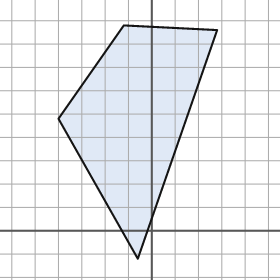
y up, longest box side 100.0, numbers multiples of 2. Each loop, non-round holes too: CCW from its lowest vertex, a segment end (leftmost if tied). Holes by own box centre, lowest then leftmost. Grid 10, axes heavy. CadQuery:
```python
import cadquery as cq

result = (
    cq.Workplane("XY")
    .moveTo(-6.0, -12.0)
    .lineTo(28.0, 86.0)
    .lineTo(-12.0, 88.0)
    .lineTo(-40.0, 48.0)
    .close()
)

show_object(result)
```